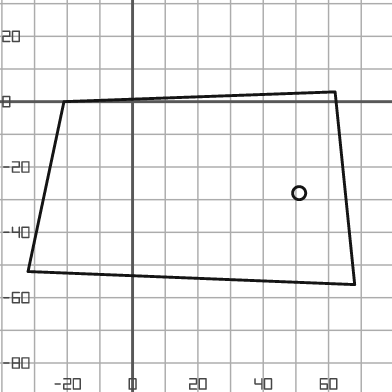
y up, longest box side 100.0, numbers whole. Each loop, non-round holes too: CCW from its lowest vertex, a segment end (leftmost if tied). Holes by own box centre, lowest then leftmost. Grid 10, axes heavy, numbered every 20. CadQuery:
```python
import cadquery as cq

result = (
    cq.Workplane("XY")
    .moveTo(68.0, -56.0)
    .lineTo(62.0, 3.0)
    .lineTo(-21.0, 0.0)
    .lineTo(-32.0, -52.0)
    .close()
    .moveTo(51.0, -28.0)
    .circle(2.0)
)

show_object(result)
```